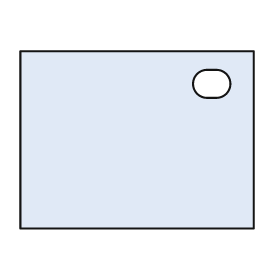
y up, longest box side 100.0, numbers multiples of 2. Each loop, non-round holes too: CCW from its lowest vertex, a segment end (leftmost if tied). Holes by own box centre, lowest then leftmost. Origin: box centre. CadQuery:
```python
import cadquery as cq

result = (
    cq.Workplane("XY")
    .moveTo(-50.0, -38.0)
    .lineTo(50.0, -38.0)
    .lineTo(50.0, 38.0)
    .lineTo(-50.0, 38.0)
    .close()
    .moveTo(30.0, 18.0)
    .lineTo(34.0, 18.0)
    .threePointArc((40.0, 24.0), (34.0, 30.0))
    .lineTo(30.0, 30.0)
    .threePointArc((24.0, 24.0), (30.0, 18.0))
    .close()
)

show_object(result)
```